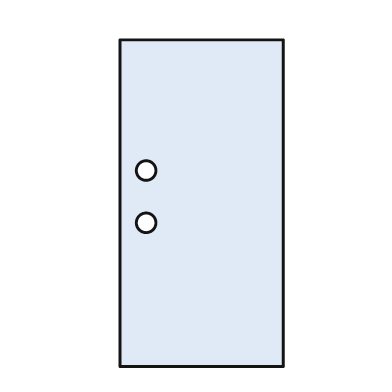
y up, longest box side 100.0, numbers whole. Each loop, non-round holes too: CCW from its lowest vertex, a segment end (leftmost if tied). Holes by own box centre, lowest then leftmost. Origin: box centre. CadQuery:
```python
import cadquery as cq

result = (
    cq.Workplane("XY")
    .moveTo(-25.0, -50.0)
    .lineTo(25.0, -50.0)
    .lineTo(25.0, 50.0)
    .lineTo(-25.0, 50.0)
    .close()
    .moveTo(-17.0, -6.0)
    .circle(3.0)
    .moveTo(-17.0, 10.0)
    .circle(3.0)
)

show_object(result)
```